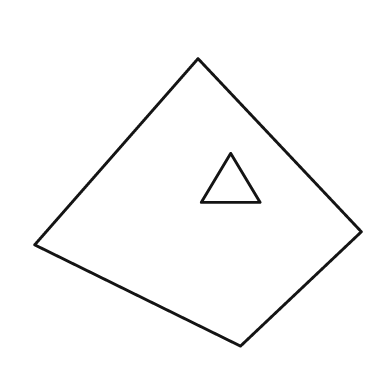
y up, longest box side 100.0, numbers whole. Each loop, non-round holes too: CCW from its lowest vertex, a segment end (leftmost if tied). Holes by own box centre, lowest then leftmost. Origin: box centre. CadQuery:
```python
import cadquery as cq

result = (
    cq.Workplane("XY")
    .moveTo(13.0, -44.0)
    .lineTo(50.0, -9.0)
    .lineTo(0.0, 44.0)
    .lineTo(-50.0, -13.0)
    .close()
    .moveTo(1.0, 0.0)
    .lineTo(19.0, 0.0)
    .lineTo(10.0, 15.0)
    .close()
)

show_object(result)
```